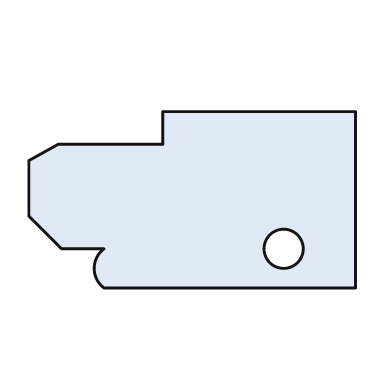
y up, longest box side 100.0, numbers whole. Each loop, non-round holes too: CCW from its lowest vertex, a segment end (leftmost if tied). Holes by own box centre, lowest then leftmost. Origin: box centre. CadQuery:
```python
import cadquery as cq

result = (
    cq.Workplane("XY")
    .moveTo(-27.0, -27.0)
    .lineTo(50.0, -27.0)
    .lineTo(50.0, 27.0)
    .lineTo(-9.0, 27.0)
    .lineTo(-9.0, 17.0)
    .lineTo(-41.0, 17.0)
    .lineTo(-50.0, 12.0)
    .lineTo(-50.0, -5.0)
    .lineTo(-40.0, -15.0)
    .lineTo(-27.0, -15.0)
    .threePointArc((-30.0, -21.0), (-27.0, -27.0))
    .close()
    .moveTo(28.0, -15.0)
    .circle(6.0)
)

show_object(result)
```